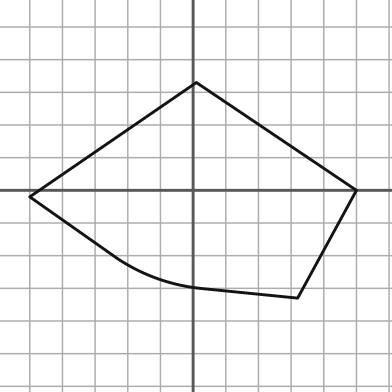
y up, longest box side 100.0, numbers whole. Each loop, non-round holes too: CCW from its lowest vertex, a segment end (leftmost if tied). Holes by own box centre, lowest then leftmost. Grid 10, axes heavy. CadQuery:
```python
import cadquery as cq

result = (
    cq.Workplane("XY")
    .moveTo(32.0, -33.0)
    .lineTo(50.0, 0.0)
    .lineTo(1.0, 33.0)
    .lineTo(-50.0, -2.0)
    .lineTo(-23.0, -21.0)
    .threePointArc((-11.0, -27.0), (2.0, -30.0))
    .close()
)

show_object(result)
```